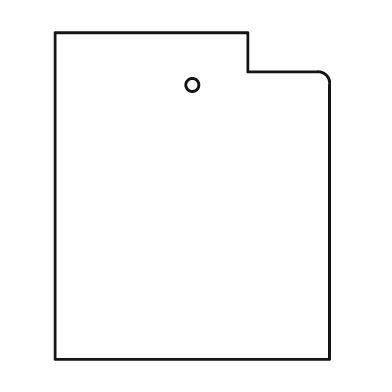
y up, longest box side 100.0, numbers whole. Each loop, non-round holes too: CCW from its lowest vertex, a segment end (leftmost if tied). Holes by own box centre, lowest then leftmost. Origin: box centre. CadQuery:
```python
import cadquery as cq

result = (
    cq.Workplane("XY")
    .moveTo(-42.0, -50.0)
    .lineTo(42.0, -50.0)
    .lineTo(42.0, 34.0)
    .threePointArc((41.0, 37.0), (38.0, 38.0))
    .lineTo(17.0, 38.0)
    .lineTo(17.0, 50.0)
    .lineTo(-42.0, 50.0)
    .close()
    .moveTo(0.0, 34.0)
    .circle(2.0)
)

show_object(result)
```